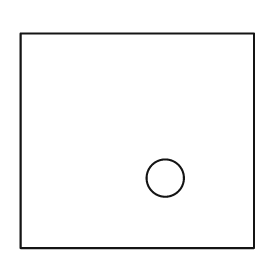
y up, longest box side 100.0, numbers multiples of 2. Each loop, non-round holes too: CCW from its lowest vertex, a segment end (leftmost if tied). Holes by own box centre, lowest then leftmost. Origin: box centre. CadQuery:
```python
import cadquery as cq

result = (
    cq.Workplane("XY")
    .moveTo(-50.0, -46.0)
    .lineTo(50.0, -46.0)
    .lineTo(50.0, 46.0)
    .lineTo(-50.0, 46.0)
    .close()
    .moveTo(12.0, -16.0)
    .circle(8.0)
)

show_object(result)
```